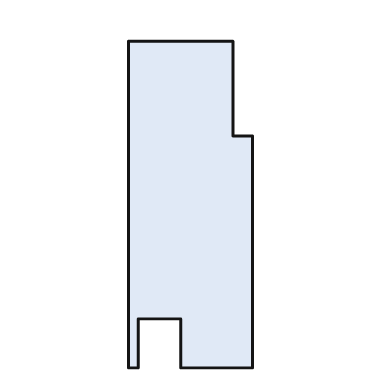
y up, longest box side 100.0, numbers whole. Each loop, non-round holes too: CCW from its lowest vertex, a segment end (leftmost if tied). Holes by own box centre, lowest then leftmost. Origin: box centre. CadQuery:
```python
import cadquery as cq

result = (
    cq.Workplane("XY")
    .moveTo(-19.0, -50.0)
    .lineTo(-16.0, -50.0)
    .lineTo(-16.0, -35.0)
    .lineTo(-3.0, -35.0)
    .lineTo(-3.0, -50.0)
    .lineTo(19.0, -50.0)
    .lineTo(19.0, 21.0)
    .lineTo(13.0, 21.0)
    .lineTo(13.0, 50.0)
    .lineTo(-19.0, 50.0)
    .close()
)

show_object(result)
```